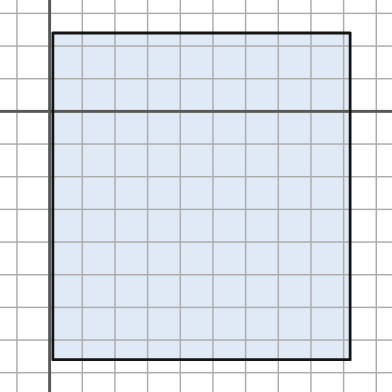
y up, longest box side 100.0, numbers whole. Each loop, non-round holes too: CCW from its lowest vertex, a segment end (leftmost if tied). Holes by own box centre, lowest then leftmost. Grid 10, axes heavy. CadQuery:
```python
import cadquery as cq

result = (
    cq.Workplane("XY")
    .moveTo(1.0, -76.0)
    .lineTo(92.0, -76.0)
    .lineTo(92.0, 24.0)
    .lineTo(1.0, 24.0)
    .close()
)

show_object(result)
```